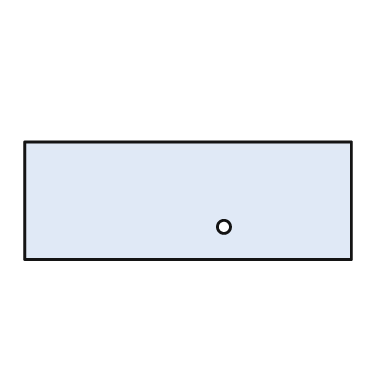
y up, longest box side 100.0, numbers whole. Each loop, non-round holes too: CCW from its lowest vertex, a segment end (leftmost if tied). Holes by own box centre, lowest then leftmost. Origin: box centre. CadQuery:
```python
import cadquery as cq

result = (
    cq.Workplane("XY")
    .moveTo(-50.0, -18.0)
    .lineTo(50.0, -18.0)
    .lineTo(50.0, 18.0)
    .lineTo(-50.0, 18.0)
    .close()
    .moveTo(11.0, -8.0)
    .circle(2.0)
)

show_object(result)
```